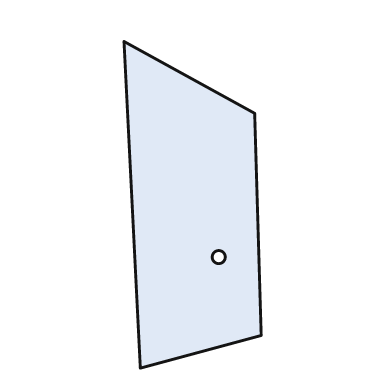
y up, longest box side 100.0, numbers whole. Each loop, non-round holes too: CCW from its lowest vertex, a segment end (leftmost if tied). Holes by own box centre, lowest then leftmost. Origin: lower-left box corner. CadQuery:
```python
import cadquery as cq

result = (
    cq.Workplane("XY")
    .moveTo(5.0, 0.0)
    .lineTo(42.0, 10.0)
    .lineTo(40.0, 78.0)
    .lineTo(0.0, 100.0)
    .close()
    .moveTo(29.0, 34.0)
    .circle(2.0)
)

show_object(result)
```